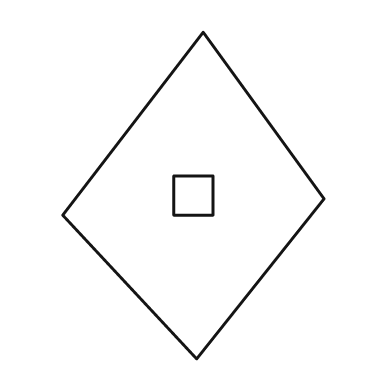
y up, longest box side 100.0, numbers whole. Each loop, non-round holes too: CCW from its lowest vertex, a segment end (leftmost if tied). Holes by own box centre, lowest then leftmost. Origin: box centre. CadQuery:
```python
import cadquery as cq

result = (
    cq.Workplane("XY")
    .moveTo(1.0, -50.0)
    .lineTo(40.0, -1.0)
    .lineTo(3.0, 50.0)
    .lineTo(-40.0, -6.0)
    .close()
    .moveTo(-6.0, -6.0)
    .lineTo(6.0, -6.0)
    .lineTo(6.0, 6.0)
    .lineTo(-6.0, 6.0)
    .close()
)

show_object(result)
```